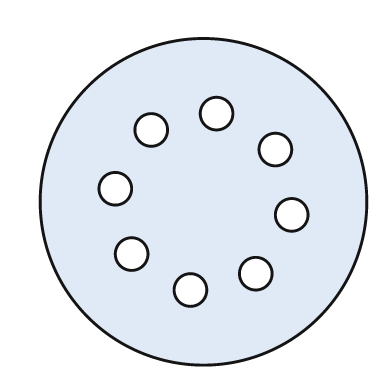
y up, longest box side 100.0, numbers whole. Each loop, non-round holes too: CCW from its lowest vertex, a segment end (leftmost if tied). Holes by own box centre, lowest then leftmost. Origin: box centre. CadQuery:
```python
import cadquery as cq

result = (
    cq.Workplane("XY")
    .moveTo(0.0, 0.0)
    .circle(50.0)
    .moveTo(-4.0, -27.0)
    .circle(5.0)
    .moveTo(16.0, -22.0)
    .circle(5.0)
    .moveTo(-22.0, -16.0)
    .circle(5.0)
    .moveTo(27.0, -4.0)
    .circle(5.0)
    .moveTo(-27.0, 4.0)
    .circle(5.0)
    .moveTo(22.0, 16.0)
    .circle(5.0)
    .moveTo(-16.0, 22.0)
    .circle(5.0)
    .moveTo(4.0, 27.0)
    .circle(5.0)
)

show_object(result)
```